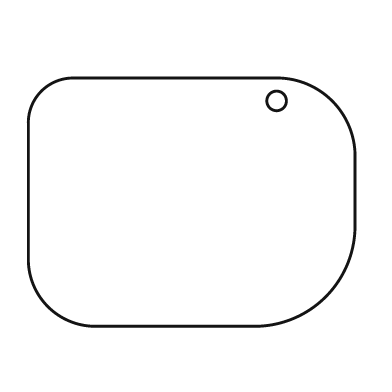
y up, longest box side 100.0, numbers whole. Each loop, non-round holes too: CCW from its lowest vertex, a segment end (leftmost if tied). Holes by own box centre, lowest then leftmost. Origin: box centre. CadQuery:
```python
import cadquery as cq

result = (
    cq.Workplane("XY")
    .moveTo(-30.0, -38.0)
    .lineTo(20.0, -38.0)
    .threePointArc((41.0, -29.0), (50.0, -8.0))
    .lineTo(50.0, 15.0)
    .threePointArc((43.0, 31.0), (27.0, 38.0))
    .lineTo(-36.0, 38.0)
    .threePointArc((-46.0, 34.0), (-50.0, 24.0))
    .lineTo(-50.0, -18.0)
    .threePointArc((-44.0, -32.0), (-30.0, -38.0))
    .close()
    .moveTo(26.0, 31.0)
    .circle(3.0)
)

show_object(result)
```